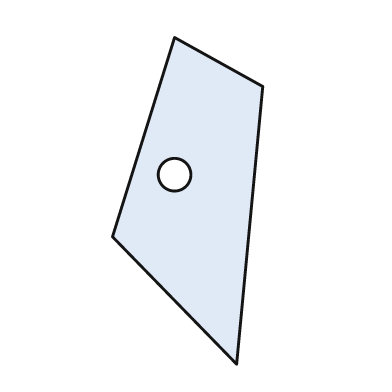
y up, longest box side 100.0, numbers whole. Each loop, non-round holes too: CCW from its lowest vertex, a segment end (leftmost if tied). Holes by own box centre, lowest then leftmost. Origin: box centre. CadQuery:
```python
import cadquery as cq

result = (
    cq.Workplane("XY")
    .moveTo(15.0, -50.0)
    .lineTo(23.0, 35.0)
    .lineTo(-4.0, 50.0)
    .lineTo(-23.0, -11.0)
    .close()
    .moveTo(-4.0, 8.0)
    .circle(5.0)
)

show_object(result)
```